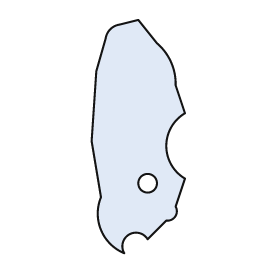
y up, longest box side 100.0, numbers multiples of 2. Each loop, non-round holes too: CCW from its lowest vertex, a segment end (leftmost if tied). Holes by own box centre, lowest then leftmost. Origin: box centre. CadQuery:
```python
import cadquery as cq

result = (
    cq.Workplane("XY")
    .moveTo(-6.0, -50.0)
    .threePointArc((-4.0, -42.0), (4.0, -44.0))
    .lineTo(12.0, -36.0)
    .threePointArc((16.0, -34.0), (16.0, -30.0))
    .lineTo(20.0, -18.0)
    .threePointArc((12.0, -4.0), (20.0, 10.0))
    .lineTo(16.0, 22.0)
    .threePointArc((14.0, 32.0), (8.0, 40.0))
    .lineTo(0.0, 50.0)
    .lineTo(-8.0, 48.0)
    .threePointArc((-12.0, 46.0), (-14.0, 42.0))
    .lineTo(-18.0, 28.0)
    .lineTo(-20.0, -2.0)
    .lineTo(-16.0, -26.0)
    .threePointArc((-16.0, -40.0), (-6.0, -50.0))
    .close()
    .moveTo(4.0, -20.0)
    .circle(4.0)
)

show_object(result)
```